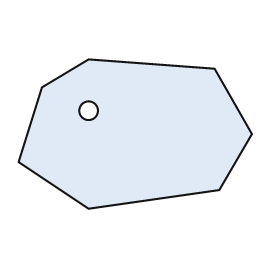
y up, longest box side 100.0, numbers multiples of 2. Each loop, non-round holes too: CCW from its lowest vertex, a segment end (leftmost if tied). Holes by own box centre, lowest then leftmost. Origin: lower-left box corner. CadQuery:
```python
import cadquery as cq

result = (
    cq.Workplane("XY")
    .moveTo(30.0, 0.0)
    .lineTo(86.0, 8.0)
    .lineTo(100.0, 32.0)
    .lineTo(84.0, 60.0)
    .lineTo(30.0, 64.0)
    .lineTo(10.0, 52.0)
    .lineTo(0.0, 20.0)
    .close()
    .moveTo(30.0, 42.0)
    .circle(4.0)
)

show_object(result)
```